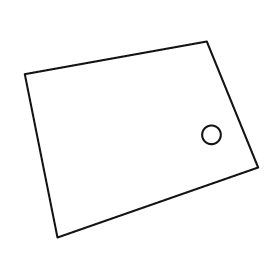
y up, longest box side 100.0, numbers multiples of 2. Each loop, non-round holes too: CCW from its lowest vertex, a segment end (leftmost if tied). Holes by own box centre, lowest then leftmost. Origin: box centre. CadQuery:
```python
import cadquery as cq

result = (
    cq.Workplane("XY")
    .moveTo(-36.0, -42.0)
    .lineTo(50.0, -12.0)
    .lineTo(28.0, 42.0)
    .lineTo(-50.0, 28.0)
    .close()
    .moveTo(30.0, 2.0)
    .circle(4.0)
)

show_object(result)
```